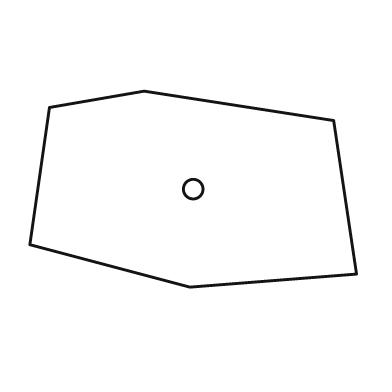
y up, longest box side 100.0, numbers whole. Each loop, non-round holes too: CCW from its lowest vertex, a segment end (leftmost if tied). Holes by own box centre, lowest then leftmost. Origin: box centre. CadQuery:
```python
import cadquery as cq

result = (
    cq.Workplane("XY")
    .moveTo(-1.0, -30.0)
    .lineTo(50.0, -26.0)
    .lineTo(43.0, 21.0)
    .lineTo(-15.0, 30.0)
    .lineTo(-44.0, 25.0)
    .lineTo(-50.0, -17.0)
    .close()
    .moveTo(0.0, 0.0)
    .circle(3.0)
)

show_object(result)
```